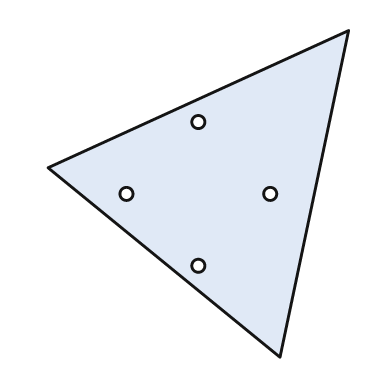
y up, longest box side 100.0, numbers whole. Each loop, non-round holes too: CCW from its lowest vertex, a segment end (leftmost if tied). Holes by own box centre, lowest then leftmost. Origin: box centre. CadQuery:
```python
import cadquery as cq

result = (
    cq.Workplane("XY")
    .moveTo(25.0, -50.0)
    .lineTo(46.0, 50.0)
    .lineTo(-46.0, 8.0)
    .close()
    .moveTo(0.0, -22.0)
    .circle(2.0)
    .moveTo(-22.0, 0.0)
    .circle(2.0)
    .moveTo(22.0, 0.0)
    .circle(2.0)
    .moveTo(0.0, 22.0)
    .circle(2.0)
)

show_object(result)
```